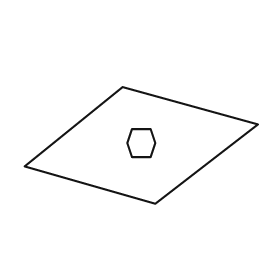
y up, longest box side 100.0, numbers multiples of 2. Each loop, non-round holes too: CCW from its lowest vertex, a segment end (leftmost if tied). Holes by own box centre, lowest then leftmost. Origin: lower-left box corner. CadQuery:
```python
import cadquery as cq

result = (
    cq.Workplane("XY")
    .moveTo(56.0, 0.0)
    .lineTo(100.0, 34.0)
    .lineTo(42.0, 50.0)
    .lineTo(0.0, 16.0)
    .close()
    .moveTo(46.0, 20.0)
    .lineTo(54.0, 20.0)
    .lineTo(56.0, 26.0)
    .lineTo(54.0, 32.0)
    .lineTo(46.0, 32.0)
    .lineTo(44.0, 26.0)
    .close()
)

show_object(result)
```